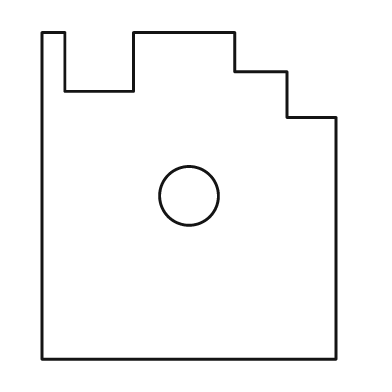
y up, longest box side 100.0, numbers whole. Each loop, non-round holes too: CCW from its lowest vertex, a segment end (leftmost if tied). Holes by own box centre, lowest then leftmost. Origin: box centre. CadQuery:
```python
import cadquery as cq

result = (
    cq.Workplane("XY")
    .moveTo(-45.0, -50.0)
    .lineTo(45.0, -50.0)
    .lineTo(45.0, 24.0)
    .lineTo(30.0, 24.0)
    .lineTo(30.0, 38.0)
    .lineTo(14.0, 38.0)
    .lineTo(14.0, 50.0)
    .lineTo(-17.0, 50.0)
    .lineTo(-17.0, 32.0)
    .lineTo(-38.0, 32.0)
    .lineTo(-38.0, 50.0)
    .lineTo(-45.0, 50.0)
    .close()
    .moveTo(0.0, 0.0)
    .circle(9.0)
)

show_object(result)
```